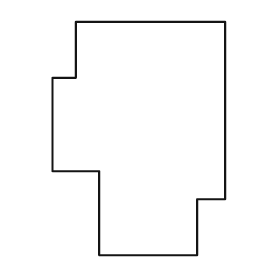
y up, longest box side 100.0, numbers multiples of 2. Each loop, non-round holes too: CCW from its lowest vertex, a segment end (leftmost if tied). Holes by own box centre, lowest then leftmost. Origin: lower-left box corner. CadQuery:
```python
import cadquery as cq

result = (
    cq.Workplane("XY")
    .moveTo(20.0, 0.0)
    .lineTo(62.0, 0.0)
    .lineTo(62.0, 24.0)
    .lineTo(74.0, 24.0)
    .lineTo(74.0, 100.0)
    .lineTo(10.0, 100.0)
    .lineTo(10.0, 76.0)
    .lineTo(0.0, 76.0)
    .lineTo(0.0, 36.0)
    .lineTo(20.0, 36.0)
    .close()
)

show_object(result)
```